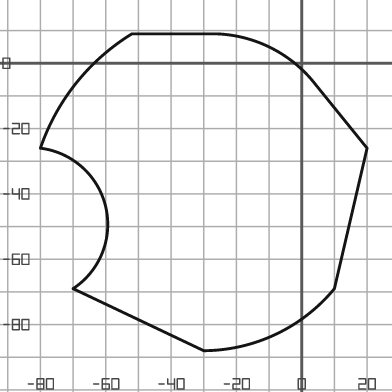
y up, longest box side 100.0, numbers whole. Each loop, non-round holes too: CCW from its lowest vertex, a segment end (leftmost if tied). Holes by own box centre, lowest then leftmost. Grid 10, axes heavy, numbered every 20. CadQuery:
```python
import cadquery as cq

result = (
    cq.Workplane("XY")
    .moveTo(-30.0, -88.0)
    .threePointArc((-8.0, -83.0), (10.0, -69.0))
    .lineTo(20.0, -26.0)
    .lineTo(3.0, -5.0)
    .threePointArc((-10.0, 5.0), (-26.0, 9.0))
    .lineTo(-52.0, 9.0)
    .threePointArc((-69.0, -6.0), (-80.0, -26.0))
    .threePointArc((-60.0, -44.0), (-70.0, -69.0))
    .close()
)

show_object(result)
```